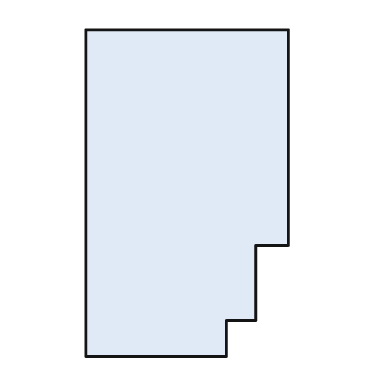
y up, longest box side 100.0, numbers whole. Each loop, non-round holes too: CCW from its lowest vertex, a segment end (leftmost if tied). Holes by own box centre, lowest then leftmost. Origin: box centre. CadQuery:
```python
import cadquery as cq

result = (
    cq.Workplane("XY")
    .moveTo(-31.0, -50.0)
    .lineTo(12.0, -50.0)
    .lineTo(12.0, -39.0)
    .lineTo(21.0, -39.0)
    .lineTo(21.0, -16.0)
    .lineTo(31.0, -16.0)
    .lineTo(31.0, 50.0)
    .lineTo(-31.0, 50.0)
    .close()
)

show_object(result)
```